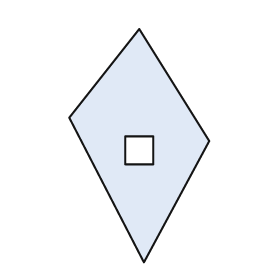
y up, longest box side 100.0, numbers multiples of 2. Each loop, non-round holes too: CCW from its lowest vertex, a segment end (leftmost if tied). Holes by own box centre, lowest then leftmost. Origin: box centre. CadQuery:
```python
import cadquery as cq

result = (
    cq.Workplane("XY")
    .moveTo(2.0, -50.0)
    .lineTo(30.0, 2.0)
    .lineTo(0.0, 50.0)
    .lineTo(-30.0, 12.0)
    .close()
    .moveTo(-6.0, -8.0)
    .lineTo(6.0, -8.0)
    .lineTo(6.0, 4.0)
    .lineTo(-6.0, 4.0)
    .close()
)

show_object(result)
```